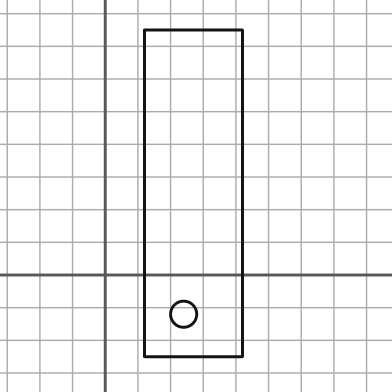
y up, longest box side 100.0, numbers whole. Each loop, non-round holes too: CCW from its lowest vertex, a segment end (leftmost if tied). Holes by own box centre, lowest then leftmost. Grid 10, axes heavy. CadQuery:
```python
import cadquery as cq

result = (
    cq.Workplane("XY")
    .moveTo(12.0, -25.0)
    .lineTo(42.0, -25.0)
    .lineTo(42.0, 75.0)
    .lineTo(12.0, 75.0)
    .close()
    .moveTo(24.0, -12.0)
    .circle(4.0)
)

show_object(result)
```